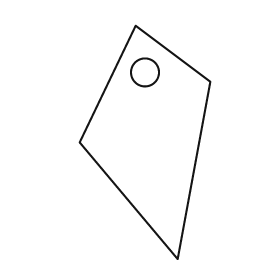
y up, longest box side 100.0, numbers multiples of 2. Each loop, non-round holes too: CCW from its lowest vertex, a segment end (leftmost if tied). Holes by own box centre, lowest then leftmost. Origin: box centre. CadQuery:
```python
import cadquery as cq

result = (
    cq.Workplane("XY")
    .moveTo(14.0, -50.0)
    .lineTo(28.0, 26.0)
    .lineTo(-4.0, 50.0)
    .lineTo(-28.0, 0.0)
    .close()
    .moveTo(0.0, 30.0)
    .circle(6.0)
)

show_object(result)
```